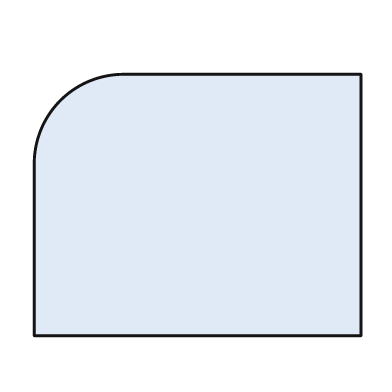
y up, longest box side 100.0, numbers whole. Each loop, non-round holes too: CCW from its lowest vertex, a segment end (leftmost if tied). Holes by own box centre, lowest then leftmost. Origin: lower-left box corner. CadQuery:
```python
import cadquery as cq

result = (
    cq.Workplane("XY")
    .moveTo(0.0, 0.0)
    .lineTo(100.0, 0.0)
    .lineTo(100.0, 80.0)
    .lineTo(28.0, 80.0)
    .threePointArc((8.0, 72.0), (0.0, 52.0))
    .close()
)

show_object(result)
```